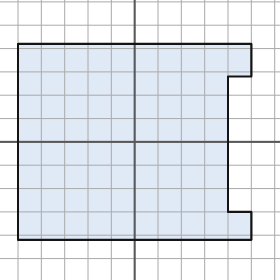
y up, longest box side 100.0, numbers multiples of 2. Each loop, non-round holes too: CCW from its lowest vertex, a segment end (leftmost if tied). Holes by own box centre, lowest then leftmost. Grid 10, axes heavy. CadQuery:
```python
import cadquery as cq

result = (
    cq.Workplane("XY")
    .moveTo(-50.0, -42.0)
    .lineTo(50.0, -42.0)
    .lineTo(50.0, -30.0)
    .lineTo(40.0, -30.0)
    .lineTo(40.0, 28.0)
    .lineTo(50.0, 28.0)
    .lineTo(50.0, 42.0)
    .lineTo(-50.0, 42.0)
    .close()
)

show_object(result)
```